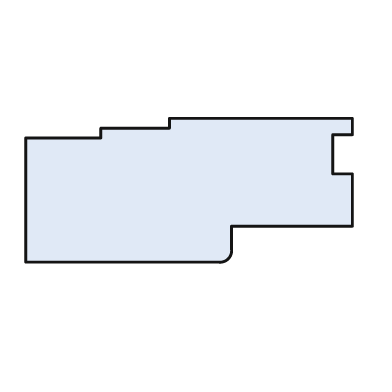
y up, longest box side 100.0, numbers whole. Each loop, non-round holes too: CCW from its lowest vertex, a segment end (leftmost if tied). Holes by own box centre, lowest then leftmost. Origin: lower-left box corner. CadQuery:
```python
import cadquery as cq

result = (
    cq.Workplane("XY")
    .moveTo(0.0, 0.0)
    .lineTo(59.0, 0.0)
    .threePointArc((62.0, 1.0), (63.0, 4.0))
    .lineTo(63.0, 11.0)
    .lineTo(100.0, 11.0)
    .lineTo(100.0, 27.0)
    .lineTo(94.0, 27.0)
    .lineTo(94.0, 39.0)
    .lineTo(100.0, 39.0)
    .lineTo(100.0, 44.0)
    .lineTo(44.0, 44.0)
    .lineTo(44.0, 41.0)
    .lineTo(23.0, 41.0)
    .lineTo(23.0, 38.0)
    .lineTo(0.0, 38.0)
    .close()
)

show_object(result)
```